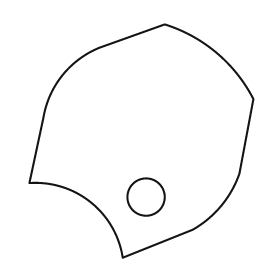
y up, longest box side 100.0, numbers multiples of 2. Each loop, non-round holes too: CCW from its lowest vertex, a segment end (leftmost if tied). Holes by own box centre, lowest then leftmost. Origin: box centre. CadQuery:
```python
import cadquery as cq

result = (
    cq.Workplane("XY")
    .moveTo(-8.0, -50.0)
    .lineTo(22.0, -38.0)
    .threePointArc((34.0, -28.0), (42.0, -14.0))
    .lineTo(48.0, 18.0)
    .threePointArc((32.0, 38.0), (10.0, 50.0))
    .lineTo(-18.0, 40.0)
    .threePointArc((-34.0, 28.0), (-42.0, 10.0))
    .lineTo(-48.0, -18.0)
    .threePointArc((-22.0, -26.0), (-8.0, -50.0))
    .close()
    .moveTo(2.0, -24.0)
    .circle(8.0)
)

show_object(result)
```